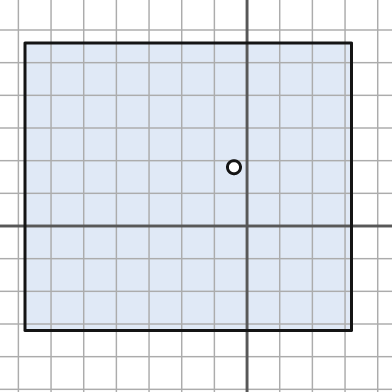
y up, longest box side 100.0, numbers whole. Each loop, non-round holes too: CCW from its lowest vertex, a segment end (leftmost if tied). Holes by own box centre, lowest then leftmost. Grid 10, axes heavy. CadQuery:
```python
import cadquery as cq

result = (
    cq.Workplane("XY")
    .moveTo(-68.0, -32.0)
    .lineTo(32.0, -32.0)
    .lineTo(32.0, 56.0)
    .lineTo(-68.0, 56.0)
    .close()
    .moveTo(-4.0, 18.0)
    .circle(2.0)
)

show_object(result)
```